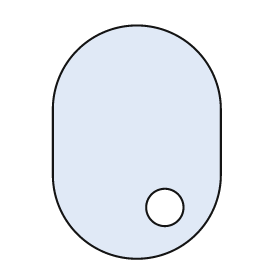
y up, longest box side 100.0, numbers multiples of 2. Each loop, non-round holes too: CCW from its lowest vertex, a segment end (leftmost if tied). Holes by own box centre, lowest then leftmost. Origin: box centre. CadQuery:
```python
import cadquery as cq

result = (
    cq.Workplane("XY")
    .moveTo(-36.0, -14.0)
    .threePointArc((0.0, -50.0), (36.0, -14.0))
    .lineTo(36.0, 14.0)
    .threePointArc((0.0, 50.0), (-36.0, 14.0))
    .close()
    .moveTo(12.0, -28.0)
    .circle(8.0)
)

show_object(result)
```